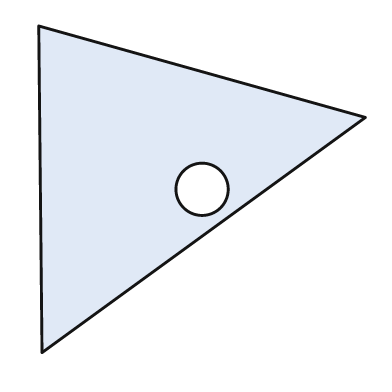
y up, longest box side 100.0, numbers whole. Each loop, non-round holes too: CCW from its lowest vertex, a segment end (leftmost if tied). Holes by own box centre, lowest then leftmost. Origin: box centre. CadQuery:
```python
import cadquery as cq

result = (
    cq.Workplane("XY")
    .moveTo(-49.0, -50.0)
    .lineTo(50.0, 22.0)
    .lineTo(-50.0, 50.0)
    .close()
    .moveTo(0.0, 0.0)
    .circle(8.0)
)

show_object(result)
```